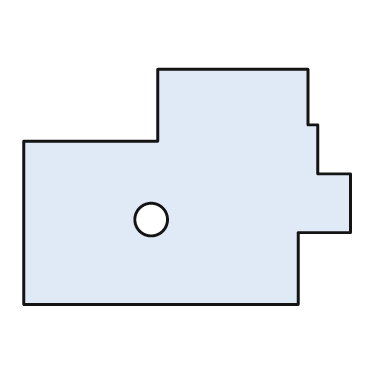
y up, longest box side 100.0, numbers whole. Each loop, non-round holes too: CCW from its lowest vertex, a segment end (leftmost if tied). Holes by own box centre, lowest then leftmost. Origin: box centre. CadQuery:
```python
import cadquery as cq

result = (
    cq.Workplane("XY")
    .moveTo(-50.0, -36.0)
    .lineTo(34.0, -36.0)
    .lineTo(34.0, -14.0)
    .lineTo(50.0, -14.0)
    .lineTo(50.0, 4.0)
    .lineTo(40.0, 4.0)
    .lineTo(40.0, 19.0)
    .lineTo(37.0, 19.0)
    .lineTo(37.0, 36.0)
    .lineTo(-9.0, 36.0)
    .lineTo(-9.0, 14.0)
    .lineTo(-50.0, 14.0)
    .close()
    .moveTo(-11.0, -10.0)
    .circle(5.0)
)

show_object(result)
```